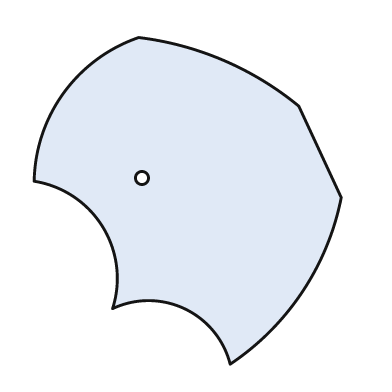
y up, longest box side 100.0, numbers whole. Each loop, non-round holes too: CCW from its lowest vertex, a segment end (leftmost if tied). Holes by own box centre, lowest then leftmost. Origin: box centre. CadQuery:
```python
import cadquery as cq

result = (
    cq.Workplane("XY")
    .moveTo(13.0, -50.0)
    .threePointArc((35.0, -28.0), (47.0, 1.0))
    .lineTo(34.0, 29.0)
    .threePointArc((11.0, 43.0), (-15.0, 50.0))
    .threePointArc((-38.0, 33.0), (-47.0, 6.0))
    .threePointArc((-26.0, -8.0), (-23.0, -33.0))
    .threePointArc((-1.0, -33.0), (13.0, -50.0))
    .close()
    .moveTo(-14.0, 7.0)
    .circle(2.0)
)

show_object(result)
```